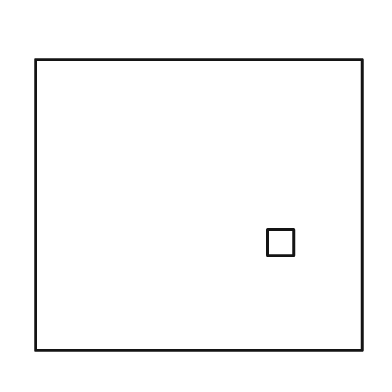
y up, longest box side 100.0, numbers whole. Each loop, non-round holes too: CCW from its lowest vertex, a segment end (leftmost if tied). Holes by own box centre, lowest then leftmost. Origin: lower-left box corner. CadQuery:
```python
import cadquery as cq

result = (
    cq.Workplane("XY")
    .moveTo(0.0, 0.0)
    .lineTo(100.0, 0.0)
    .lineTo(100.0, 89.0)
    .lineTo(0.0, 89.0)
    .close()
    .moveTo(71.0, 29.0)
    .lineTo(79.0, 29.0)
    .lineTo(79.0, 37.0)
    .lineTo(71.0, 37.0)
    .close()
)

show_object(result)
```